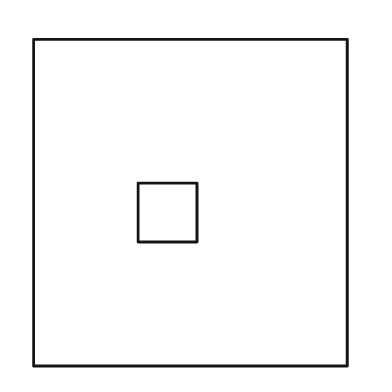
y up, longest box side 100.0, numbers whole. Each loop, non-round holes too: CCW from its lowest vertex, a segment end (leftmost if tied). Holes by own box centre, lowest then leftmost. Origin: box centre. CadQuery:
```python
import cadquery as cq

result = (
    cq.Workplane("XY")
    .moveTo(-48.0, -50.0)
    .lineTo(48.0, -50.0)
    .lineTo(48.0, 50.0)
    .lineTo(-48.0, 50.0)
    .close()
    .moveTo(-16.0, -12.0)
    .lineTo(2.0, -12.0)
    .lineTo(2.0, 6.0)
    .lineTo(-16.0, 6.0)
    .close()
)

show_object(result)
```